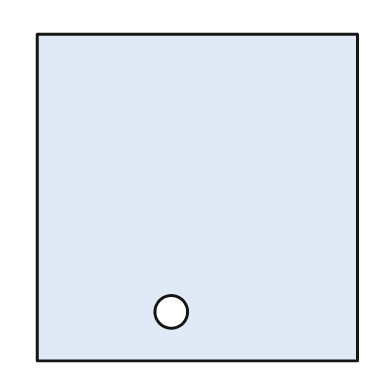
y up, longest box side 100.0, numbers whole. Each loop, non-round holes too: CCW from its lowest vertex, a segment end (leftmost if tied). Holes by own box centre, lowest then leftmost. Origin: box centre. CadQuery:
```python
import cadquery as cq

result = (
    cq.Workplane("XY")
    .moveTo(-49.0, -50.0)
    .lineTo(49.0, -50.0)
    .lineTo(49.0, 50.0)
    .lineTo(-49.0, 50.0)
    .close()
    .moveTo(-8.0, -35.0)
    .circle(5.0)
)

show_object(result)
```